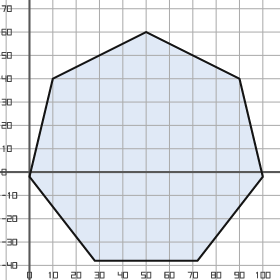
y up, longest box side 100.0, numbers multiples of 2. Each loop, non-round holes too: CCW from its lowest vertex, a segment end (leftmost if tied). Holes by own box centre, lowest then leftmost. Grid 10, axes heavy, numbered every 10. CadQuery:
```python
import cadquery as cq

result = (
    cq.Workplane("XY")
    .moveTo(28.0, -38.0)
    .lineTo(72.0, -38.0)
    .lineTo(100.0, -2.0)
    .lineTo(90.0, 40.0)
    .lineTo(50.0, 60.0)
    .lineTo(10.0, 40.0)
    .lineTo(0.0, -2.0)
    .close()
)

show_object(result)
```